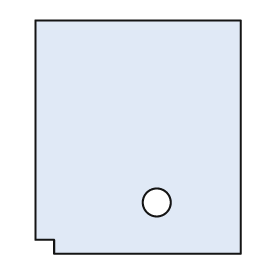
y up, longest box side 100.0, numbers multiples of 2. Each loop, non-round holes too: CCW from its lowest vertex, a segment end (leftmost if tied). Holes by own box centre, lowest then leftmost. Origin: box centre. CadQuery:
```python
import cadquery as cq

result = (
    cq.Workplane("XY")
    .moveTo(-36.0, -50.0)
    .lineTo(44.0, -50.0)
    .lineTo(44.0, 50.0)
    .lineTo(-44.0, 50.0)
    .lineTo(-44.0, -44.0)
    .lineTo(-36.0, -44.0)
    .close()
    .moveTo(8.0, -28.0)
    .circle(6.0)
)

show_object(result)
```